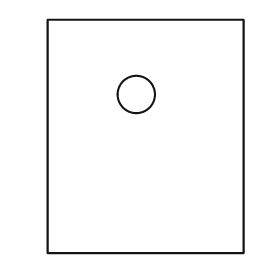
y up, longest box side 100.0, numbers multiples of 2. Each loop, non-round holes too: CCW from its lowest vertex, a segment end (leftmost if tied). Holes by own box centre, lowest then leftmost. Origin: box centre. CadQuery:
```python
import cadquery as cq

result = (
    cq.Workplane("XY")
    .moveTo(-42.0, -50.0)
    .lineTo(42.0, -50.0)
    .lineTo(42.0, 50.0)
    .lineTo(-42.0, 50.0)
    .close()
    .moveTo(-4.0, 18.0)
    .circle(8.0)
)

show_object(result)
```